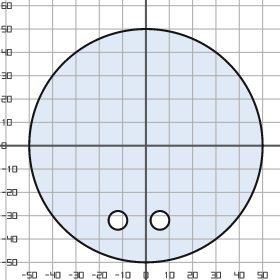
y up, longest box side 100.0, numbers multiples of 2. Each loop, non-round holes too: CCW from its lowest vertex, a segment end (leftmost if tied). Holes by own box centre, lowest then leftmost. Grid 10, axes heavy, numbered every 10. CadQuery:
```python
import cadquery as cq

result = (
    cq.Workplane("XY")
    .moveTo(0.0, 0.0)
    .circle(50.0)
    .moveTo(-12.0, -32.0)
    .circle(4.0)
    .moveTo(6.0, -32.0)
    .circle(4.0)
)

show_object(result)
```